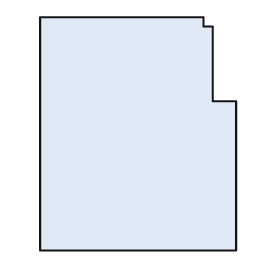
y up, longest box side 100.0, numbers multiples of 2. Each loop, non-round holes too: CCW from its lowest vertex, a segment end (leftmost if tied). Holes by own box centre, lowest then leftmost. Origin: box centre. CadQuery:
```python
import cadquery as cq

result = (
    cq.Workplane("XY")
    .moveTo(-42.0, -50.0)
    .lineTo(42.0, -50.0)
    .lineTo(42.0, 14.0)
    .lineTo(32.0, 14.0)
    .lineTo(32.0, 46.0)
    .lineTo(28.0, 46.0)
    .lineTo(28.0, 50.0)
    .lineTo(-42.0, 50.0)
    .close()
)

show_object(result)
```